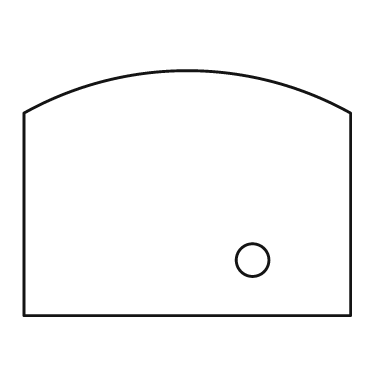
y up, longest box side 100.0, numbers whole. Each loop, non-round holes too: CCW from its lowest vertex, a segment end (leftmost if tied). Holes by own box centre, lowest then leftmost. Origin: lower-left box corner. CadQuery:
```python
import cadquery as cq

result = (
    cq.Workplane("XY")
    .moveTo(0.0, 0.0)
    .lineTo(100.0, 0.0)
    .lineTo(100.0, 62.0)
    .threePointArc((50.0, 75.0), (0.0, 62.0))
    .close()
    .moveTo(70.0, 17.0)
    .circle(5.0)
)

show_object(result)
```